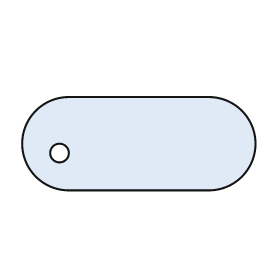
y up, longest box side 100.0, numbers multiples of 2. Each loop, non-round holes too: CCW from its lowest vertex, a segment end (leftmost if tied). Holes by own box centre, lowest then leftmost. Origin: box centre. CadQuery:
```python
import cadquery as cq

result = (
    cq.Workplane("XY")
    .moveTo(-30.0, -20.0)
    .lineTo(30.0, -20.0)
    .threePointArc((50.0, 0.0), (30.0, 20.0))
    .lineTo(-30.0, 20.0)
    .threePointArc((-50.0, 0.0), (-30.0, -20.0))
    .close()
    .moveTo(-34.0, -4.0)
    .circle(4.0)
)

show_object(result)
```